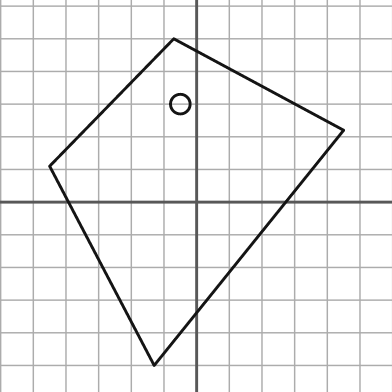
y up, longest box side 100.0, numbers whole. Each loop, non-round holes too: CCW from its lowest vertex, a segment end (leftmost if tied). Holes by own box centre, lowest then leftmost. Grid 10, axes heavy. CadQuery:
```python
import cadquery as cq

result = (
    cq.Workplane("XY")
    .moveTo(-13.0, -50.0)
    .lineTo(45.0, 22.0)
    .lineTo(-7.0, 50.0)
    .lineTo(-45.0, 11.0)
    .close()
    .moveTo(-5.0, 30.0)
    .circle(3.0)
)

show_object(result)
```